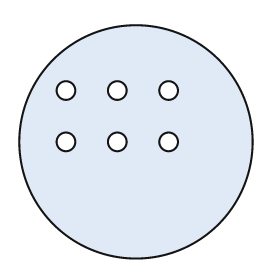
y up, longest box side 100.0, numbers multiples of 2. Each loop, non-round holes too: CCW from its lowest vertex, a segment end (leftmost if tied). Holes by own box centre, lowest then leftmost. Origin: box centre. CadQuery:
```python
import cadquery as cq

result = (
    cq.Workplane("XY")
    .moveTo(0.0, 0.0)
    .circle(50.0)
    .moveTo(-30.0, 0.0)
    .circle(4.0)
    .moveTo(-8.0, 0.0)
    .circle(4.0)
    .moveTo(14.0, 0.0)
    .circle(4.0)
    .moveTo(-30.0, 22.0)
    .circle(4.0)
    .moveTo(-8.0, 22.0)
    .circle(4.0)
    .moveTo(14.0, 22.0)
    .circle(4.0)
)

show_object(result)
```